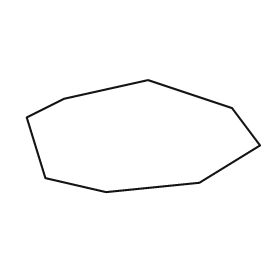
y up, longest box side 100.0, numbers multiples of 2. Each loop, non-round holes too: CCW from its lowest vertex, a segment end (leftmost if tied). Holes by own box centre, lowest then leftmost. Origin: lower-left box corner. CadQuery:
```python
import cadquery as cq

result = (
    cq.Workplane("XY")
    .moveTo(34.0, 0.0)
    .lineTo(74.0, 4.0)
    .lineTo(100.0, 20.0)
    .lineTo(88.0, 36.0)
    .lineTo(52.0, 48.0)
    .lineTo(16.0, 40.0)
    .lineTo(0.0, 32.0)
    .lineTo(8.0, 6.0)
    .close()
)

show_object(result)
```